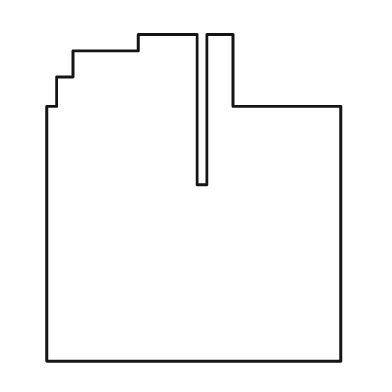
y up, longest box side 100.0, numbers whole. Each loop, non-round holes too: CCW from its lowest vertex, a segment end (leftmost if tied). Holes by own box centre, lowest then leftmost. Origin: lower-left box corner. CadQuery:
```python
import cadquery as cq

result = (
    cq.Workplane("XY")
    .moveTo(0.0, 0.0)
    .lineTo(90.0, 0.0)
    .lineTo(90.0, 78.0)
    .lineTo(57.0, 78.0)
    .lineTo(57.0, 100.0)
    .lineTo(49.0, 100.0)
    .lineTo(49.0, 54.0)
    .lineTo(46.0, 54.0)
    .lineTo(46.0, 100.0)
    .lineTo(28.0, 100.0)
    .lineTo(28.0, 95.0)
    .lineTo(8.0, 95.0)
    .lineTo(8.0, 87.0)
    .lineTo(3.0, 87.0)
    .lineTo(3.0, 78.0)
    .lineTo(0.0, 78.0)
    .close()
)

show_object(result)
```